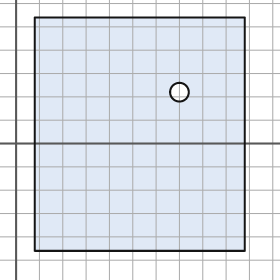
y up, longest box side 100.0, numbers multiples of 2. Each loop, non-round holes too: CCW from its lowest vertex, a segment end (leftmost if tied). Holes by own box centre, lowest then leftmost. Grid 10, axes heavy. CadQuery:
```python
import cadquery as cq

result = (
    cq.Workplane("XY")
    .moveTo(8.0, -46.0)
    .lineTo(98.0, -46.0)
    .lineTo(98.0, 54.0)
    .lineTo(8.0, 54.0)
    .close()
    .moveTo(70.0, 22.0)
    .circle(4.0)
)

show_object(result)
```